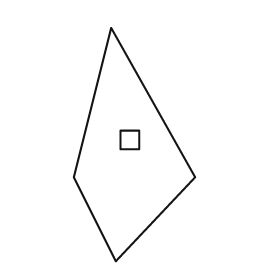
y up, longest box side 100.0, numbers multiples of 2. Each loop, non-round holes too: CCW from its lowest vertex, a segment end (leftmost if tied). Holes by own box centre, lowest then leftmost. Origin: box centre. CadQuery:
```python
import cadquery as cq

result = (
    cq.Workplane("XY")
    .moveTo(-8.0, -50.0)
    .lineTo(26.0, -14.0)
    .lineTo(-10.0, 50.0)
    .lineTo(-26.0, -14.0)
    .close()
    .moveTo(-6.0, -2.0)
    .lineTo(2.0, -2.0)
    .lineTo(2.0, 6.0)
    .lineTo(-6.0, 6.0)
    .close()
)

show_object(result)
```